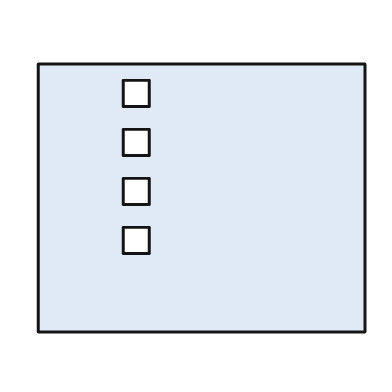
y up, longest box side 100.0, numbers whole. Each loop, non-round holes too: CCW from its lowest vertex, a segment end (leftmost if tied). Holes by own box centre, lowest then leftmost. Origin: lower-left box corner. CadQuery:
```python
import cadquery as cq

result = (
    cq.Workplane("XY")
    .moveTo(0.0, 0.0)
    .lineTo(100.0, 0.0)
    .lineTo(100.0, 82.0)
    .lineTo(0.0, 82.0)
    .close()
    .moveTo(26.0, 24.0)
    .lineTo(34.0, 24.0)
    .lineTo(34.0, 32.0)
    .lineTo(26.0, 32.0)
    .close()
    .moveTo(26.0, 39.0)
    .lineTo(34.0, 39.0)
    .lineTo(34.0, 47.0)
    .lineTo(26.0, 47.0)
    .close()
    .moveTo(26.0, 54.0)
    .lineTo(34.0, 54.0)
    .lineTo(34.0, 62.0)
    .lineTo(26.0, 62.0)
    .close()
    .moveTo(26.0, 69.0)
    .lineTo(34.0, 69.0)
    .lineTo(34.0, 77.0)
    .lineTo(26.0, 77.0)
    .close()
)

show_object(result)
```